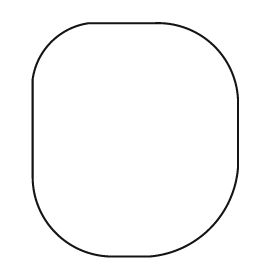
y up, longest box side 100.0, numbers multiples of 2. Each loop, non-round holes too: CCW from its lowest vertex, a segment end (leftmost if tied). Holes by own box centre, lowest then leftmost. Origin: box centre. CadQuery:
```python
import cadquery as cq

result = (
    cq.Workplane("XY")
    .moveTo(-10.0, -50.0)
    .lineTo(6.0, -50.0)
    .threePointArc((32.0, -38.0), (44.0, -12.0))
    .lineTo(44.0, 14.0)
    .threePointArc((34.0, 40.0), (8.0, 50.0))
    .lineTo(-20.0, 50.0)
    .threePointArc((-36.0, 42.0), (-44.0, 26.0))
    .lineTo(-44.0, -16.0)
    .threePointArc((-34.0, -40.0), (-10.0, -50.0))
    .close()
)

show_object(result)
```